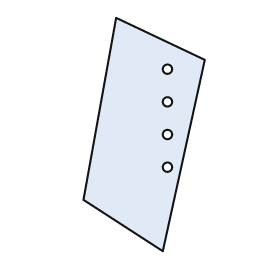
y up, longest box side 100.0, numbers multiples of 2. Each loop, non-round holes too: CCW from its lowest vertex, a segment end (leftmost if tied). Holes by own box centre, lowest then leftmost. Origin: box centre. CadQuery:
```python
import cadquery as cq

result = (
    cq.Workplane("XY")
    .moveTo(8.0, -50.0)
    .lineTo(26.0, 32.0)
    .lineTo(-12.0, 50.0)
    .lineTo(-26.0, -28.0)
    .close()
    .moveTo(10.0, -14.0)
    .circle(2.0)
    .moveTo(10.0, 0.0)
    .circle(2.0)
    .moveTo(10.0, 14.0)
    .circle(2.0)
    .moveTo(10.0, 28.0)
    .circle(2.0)
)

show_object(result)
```